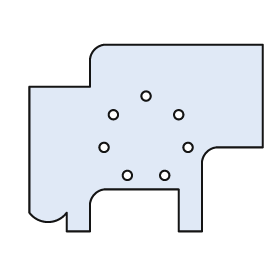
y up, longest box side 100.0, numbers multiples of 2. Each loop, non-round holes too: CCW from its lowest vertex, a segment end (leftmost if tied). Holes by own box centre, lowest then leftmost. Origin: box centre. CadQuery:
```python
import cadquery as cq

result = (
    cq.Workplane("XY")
    .moveTo(-34.0, -40.0)
    .lineTo(-24.0, -40.0)
    .lineTo(-24.0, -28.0)
    .threePointArc((-22.0, -24.0), (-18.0, -22.0))
    .lineTo(14.0, -22.0)
    .lineTo(14.0, -40.0)
    .lineTo(24.0, -40.0)
    .lineTo(24.0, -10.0)
    .threePointArc((26.0, -6.0), (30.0, -4.0))
    .lineTo(50.0, -4.0)
    .lineTo(50.0, 40.0)
    .lineTo(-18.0, 40.0)
    .threePointArc((-22.0, 38.0), (-24.0, 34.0))
    .lineTo(-24.0, 22.0)
    .lineTo(-50.0, 22.0)
    .lineTo(-50.0, -32.0)
    .threePointArc((-42.0, -36.0), (-34.0, -32.0))
    .close()
    .moveTo(-8.0, -16.0)
    .circle(2.0)
    .moveTo(8.0, -16.0)
    .circle(2.0)
    .moveTo(-18.0, -4.0)
    .circle(2.0)
    .moveTo(18.0, -4.0)
    .circle(2.0)
    .moveTo(-14.0, 10.0)
    .circle(2.0)
    .moveTo(14.0, 10.0)
    .circle(2.0)
    .moveTo(0.0, 18.0)
    .circle(2.0)
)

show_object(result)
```